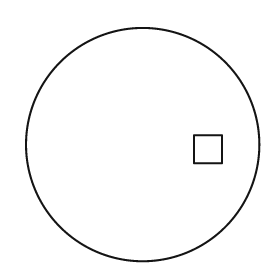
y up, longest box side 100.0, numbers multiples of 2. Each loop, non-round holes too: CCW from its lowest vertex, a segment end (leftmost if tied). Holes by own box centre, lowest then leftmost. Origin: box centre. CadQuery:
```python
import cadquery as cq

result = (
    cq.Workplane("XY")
    .moveTo(0.0, 0.0)
    .circle(50.0)
    .moveTo(22.0, -8.0)
    .lineTo(34.0, -8.0)
    .lineTo(34.0, 4.0)
    .lineTo(22.0, 4.0)
    .close()
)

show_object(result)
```